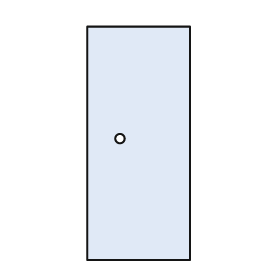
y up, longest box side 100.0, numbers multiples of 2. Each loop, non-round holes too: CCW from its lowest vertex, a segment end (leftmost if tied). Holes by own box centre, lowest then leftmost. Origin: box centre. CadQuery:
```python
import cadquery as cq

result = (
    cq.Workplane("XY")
    .moveTo(-22.0, -50.0)
    .lineTo(22.0, -50.0)
    .lineTo(22.0, 50.0)
    .lineTo(-22.0, 50.0)
    .close()
    .moveTo(-8.0, 2.0)
    .circle(2.0)
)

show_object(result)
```